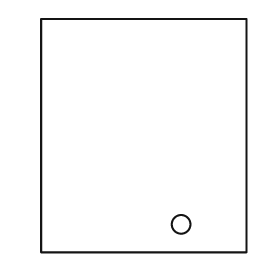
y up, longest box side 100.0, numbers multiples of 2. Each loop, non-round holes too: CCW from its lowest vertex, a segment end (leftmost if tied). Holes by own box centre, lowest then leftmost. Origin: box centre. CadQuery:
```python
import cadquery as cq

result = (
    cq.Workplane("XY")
    .moveTo(-44.0, -50.0)
    .lineTo(44.0, -50.0)
    .lineTo(44.0, 50.0)
    .lineTo(-44.0, 50.0)
    .close()
    .moveTo(16.0, -38.0)
    .circle(4.0)
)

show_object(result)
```